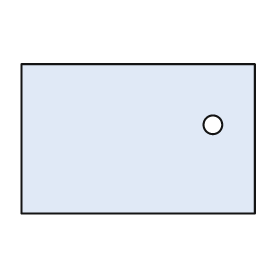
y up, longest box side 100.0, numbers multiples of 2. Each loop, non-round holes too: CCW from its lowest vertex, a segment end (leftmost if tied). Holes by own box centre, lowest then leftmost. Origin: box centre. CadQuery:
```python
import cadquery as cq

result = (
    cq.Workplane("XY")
    .moveTo(-50.0, -32.0)
    .lineTo(50.0, -32.0)
    .lineTo(50.0, 32.0)
    .lineTo(-50.0, 32.0)
    .close()
    .moveTo(32.0, 6.0)
    .circle(4.0)
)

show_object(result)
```